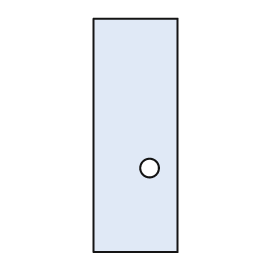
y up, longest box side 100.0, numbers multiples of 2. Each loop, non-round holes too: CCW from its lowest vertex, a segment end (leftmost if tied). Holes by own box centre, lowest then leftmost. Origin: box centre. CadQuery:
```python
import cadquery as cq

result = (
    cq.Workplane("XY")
    .moveTo(-18.0, -50.0)
    .lineTo(18.0, -50.0)
    .lineTo(18.0, 50.0)
    .lineTo(-18.0, 50.0)
    .close()
    .moveTo(6.0, -14.0)
    .circle(4.0)
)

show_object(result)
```